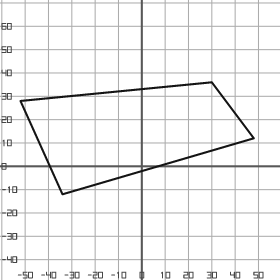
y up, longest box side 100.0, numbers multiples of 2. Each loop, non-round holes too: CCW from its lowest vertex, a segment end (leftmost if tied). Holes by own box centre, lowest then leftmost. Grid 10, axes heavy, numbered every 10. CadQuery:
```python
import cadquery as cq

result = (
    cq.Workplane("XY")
    .moveTo(-34.0, -12.0)
    .lineTo(48.0, 12.0)
    .lineTo(30.0, 36.0)
    .lineTo(-52.0, 28.0)
    .close()
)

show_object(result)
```